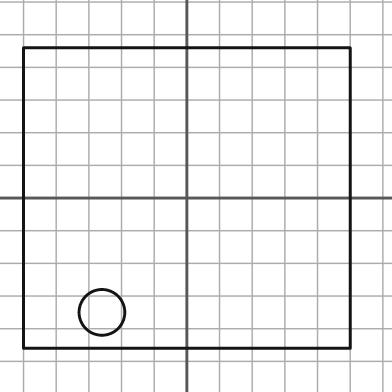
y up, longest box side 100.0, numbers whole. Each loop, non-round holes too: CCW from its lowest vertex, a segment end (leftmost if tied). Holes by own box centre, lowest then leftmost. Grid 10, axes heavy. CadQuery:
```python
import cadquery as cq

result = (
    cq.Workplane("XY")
    .moveTo(-50.0, -46.0)
    .lineTo(50.0, -46.0)
    .lineTo(50.0, 46.0)
    .lineTo(-50.0, 46.0)
    .close()
    .moveTo(-26.0, -35.0)
    .circle(7.0)
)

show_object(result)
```